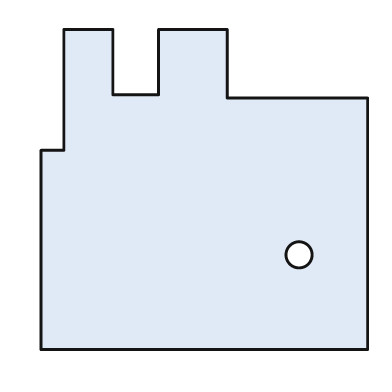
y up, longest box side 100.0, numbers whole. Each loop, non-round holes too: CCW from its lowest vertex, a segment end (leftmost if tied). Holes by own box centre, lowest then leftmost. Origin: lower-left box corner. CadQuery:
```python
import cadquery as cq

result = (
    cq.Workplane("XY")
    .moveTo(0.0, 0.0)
    .lineTo(100.0, 0.0)
    .lineTo(100.0, 77.0)
    .lineTo(57.0, 77.0)
    .lineTo(57.0, 98.0)
    .lineTo(36.0, 98.0)
    .lineTo(36.0, 78.0)
    .lineTo(22.0, 78.0)
    .lineTo(22.0, 98.0)
    .lineTo(7.0, 98.0)
    .lineTo(7.0, 61.0)
    .lineTo(0.0, 61.0)
    .close()
    .moveTo(79.0, 29.0)
    .circle(4.0)
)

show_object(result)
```